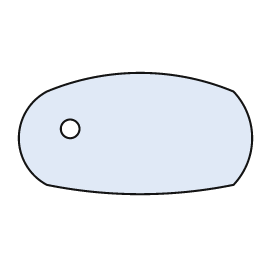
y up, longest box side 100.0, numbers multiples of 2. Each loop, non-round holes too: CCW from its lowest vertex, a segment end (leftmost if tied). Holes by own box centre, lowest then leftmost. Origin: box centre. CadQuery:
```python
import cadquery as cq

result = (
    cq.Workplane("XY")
    .moveTo(-38.0, -22.0)
    .threePointArc((2.0, -26.0), (42.0, -22.0))
    .threePointArc((50.0, -2.0), (42.0, 18.0))
    .threePointArc((2.0, 26.0), (-38.0, 18.0))
    .threePointArc((-50.0, -2.0), (-38.0, -22.0))
    .close()
    .moveTo(-28.0, 2.0)
    .circle(4.0)
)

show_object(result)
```